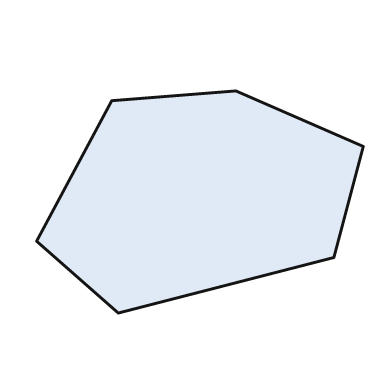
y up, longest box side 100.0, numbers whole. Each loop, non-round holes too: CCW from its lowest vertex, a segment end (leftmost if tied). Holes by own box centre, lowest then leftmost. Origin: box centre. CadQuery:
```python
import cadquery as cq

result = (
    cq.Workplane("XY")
    .moveTo(-25.0, -34.0)
    .lineTo(41.0, -17.0)
    .lineTo(50.0, 17.0)
    .lineTo(11.0, 34.0)
    .lineTo(-27.0, 31.0)
    .lineTo(-50.0, -12.0)
    .close()
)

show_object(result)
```